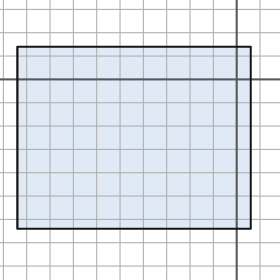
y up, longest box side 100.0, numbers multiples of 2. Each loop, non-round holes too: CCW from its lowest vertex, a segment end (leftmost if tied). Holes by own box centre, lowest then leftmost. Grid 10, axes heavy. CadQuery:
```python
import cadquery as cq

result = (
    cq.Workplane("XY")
    .moveTo(-94.0, -64.0)
    .lineTo(6.0, -64.0)
    .lineTo(6.0, 14.0)
    .lineTo(-94.0, 14.0)
    .close()
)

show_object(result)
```